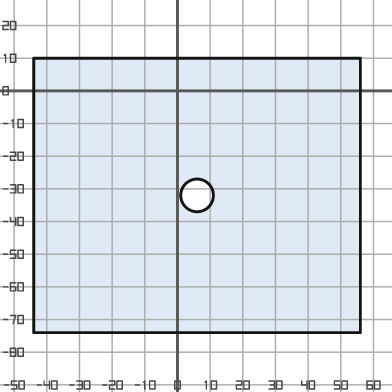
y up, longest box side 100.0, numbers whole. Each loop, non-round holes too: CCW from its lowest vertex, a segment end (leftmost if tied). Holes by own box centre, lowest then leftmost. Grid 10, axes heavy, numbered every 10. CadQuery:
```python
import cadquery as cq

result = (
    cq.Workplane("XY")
    .moveTo(-44.0, -74.0)
    .lineTo(56.0, -74.0)
    .lineTo(56.0, 10.0)
    .lineTo(-44.0, 10.0)
    .close()
    .moveTo(6.0, -32.0)
    .circle(5.0)
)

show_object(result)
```